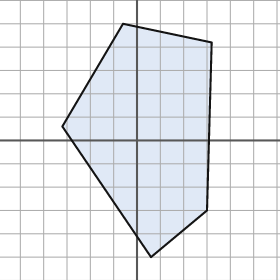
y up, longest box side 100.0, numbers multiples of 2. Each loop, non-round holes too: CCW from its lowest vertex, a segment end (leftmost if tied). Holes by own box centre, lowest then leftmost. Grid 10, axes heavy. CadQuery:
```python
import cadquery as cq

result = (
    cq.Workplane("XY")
    .moveTo(6.0, -50.0)
    .lineTo(30.0, -30.0)
    .lineTo(32.0, 42.0)
    .lineTo(-6.0, 50.0)
    .lineTo(-32.0, 6.0)
    .close()
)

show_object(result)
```